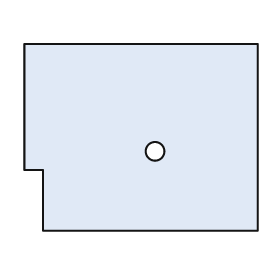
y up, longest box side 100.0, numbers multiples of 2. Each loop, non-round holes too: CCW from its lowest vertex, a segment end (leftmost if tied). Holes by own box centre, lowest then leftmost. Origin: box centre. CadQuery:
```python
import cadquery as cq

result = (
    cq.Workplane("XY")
    .moveTo(-42.0, -40.0)
    .lineTo(50.0, -40.0)
    .lineTo(50.0, 40.0)
    .lineTo(-50.0, 40.0)
    .lineTo(-50.0, -14.0)
    .lineTo(-42.0, -14.0)
    .close()
    .moveTo(6.0, -6.0)
    .circle(4.0)
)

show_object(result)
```